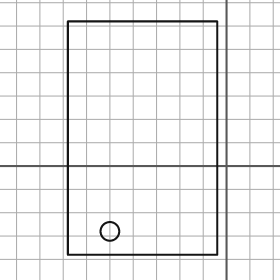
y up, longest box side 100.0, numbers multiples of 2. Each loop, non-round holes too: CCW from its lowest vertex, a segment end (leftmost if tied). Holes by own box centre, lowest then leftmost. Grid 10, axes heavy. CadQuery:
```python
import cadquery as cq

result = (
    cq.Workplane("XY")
    .moveTo(-68.0, -38.0)
    .lineTo(-4.0, -38.0)
    .lineTo(-4.0, 62.0)
    .lineTo(-68.0, 62.0)
    .close()
    .moveTo(-50.0, -28.0)
    .circle(4.0)
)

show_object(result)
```